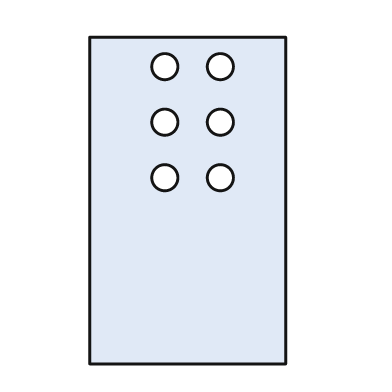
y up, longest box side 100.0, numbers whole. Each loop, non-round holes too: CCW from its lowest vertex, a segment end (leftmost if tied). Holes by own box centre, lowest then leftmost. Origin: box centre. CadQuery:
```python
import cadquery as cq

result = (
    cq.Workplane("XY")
    .moveTo(-30.0, -50.0)
    .lineTo(30.0, -50.0)
    .lineTo(30.0, 50.0)
    .lineTo(-30.0, 50.0)
    .close()
    .moveTo(-7.0, 7.0)
    .circle(4.0)
    .moveTo(10.0, 7.0)
    .circle(4.0)
    .moveTo(-7.0, 24.0)
    .circle(4.0)
    .moveTo(10.0, 24.0)
    .circle(4.0)
    .moveTo(-7.0, 41.0)
    .circle(4.0)
    .moveTo(10.0, 41.0)
    .circle(4.0)
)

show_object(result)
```